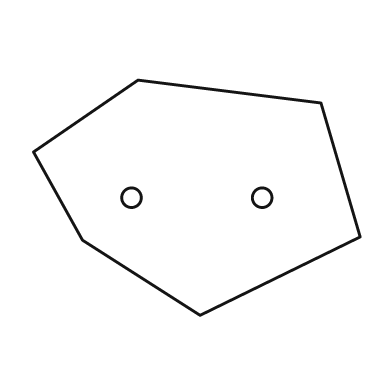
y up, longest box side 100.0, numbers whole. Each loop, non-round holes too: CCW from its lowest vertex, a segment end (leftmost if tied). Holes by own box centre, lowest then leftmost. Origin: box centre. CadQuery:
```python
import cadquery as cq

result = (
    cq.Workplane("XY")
    .moveTo(1.0, -36.0)
    .lineTo(50.0, -12.0)
    .lineTo(38.0, 29.0)
    .lineTo(-18.0, 36.0)
    .lineTo(-50.0, 14.0)
    .lineTo(-35.0, -13.0)
    .close()
    .moveTo(-20.0, 0.0)
    .circle(3.0)
    .moveTo(20.0, 0.0)
    .circle(3.0)
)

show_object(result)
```